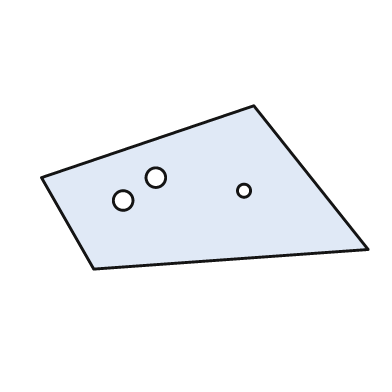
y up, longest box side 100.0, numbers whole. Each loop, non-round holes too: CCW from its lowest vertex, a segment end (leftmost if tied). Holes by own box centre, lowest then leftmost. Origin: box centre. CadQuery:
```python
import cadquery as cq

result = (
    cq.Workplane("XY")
    .moveTo(-34.0, -25.0)
    .lineTo(50.0, -19.0)
    .lineTo(15.0, 25.0)
    .lineTo(-50.0, 3.0)
    .close()
    .moveTo(-25.0, -4.0)
    .circle(3.0)
    .moveTo(12.0, -1.0)
    .circle(2.0)
    .moveTo(-15.0, 3.0)
    .circle(3.0)
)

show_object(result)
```